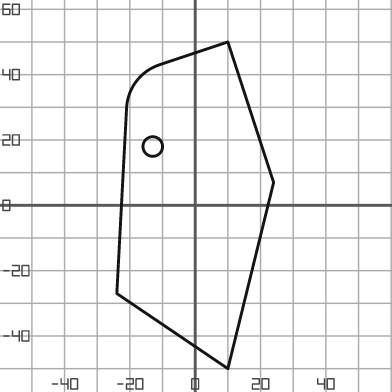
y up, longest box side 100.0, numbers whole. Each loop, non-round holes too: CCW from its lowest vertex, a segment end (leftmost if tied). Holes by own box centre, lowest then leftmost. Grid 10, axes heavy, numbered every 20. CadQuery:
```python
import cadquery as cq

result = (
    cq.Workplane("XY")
    .moveTo(10.0, -50.0)
    .lineTo(24.0, 7.0)
    .lineTo(10.0, 50.0)
    .lineTo(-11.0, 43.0)
    .threePointArc((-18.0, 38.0), (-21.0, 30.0))
    .lineTo(-24.0, -27.0)
    .close()
    .moveTo(-13.0, 18.0)
    .circle(3.0)
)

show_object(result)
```